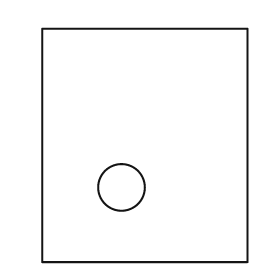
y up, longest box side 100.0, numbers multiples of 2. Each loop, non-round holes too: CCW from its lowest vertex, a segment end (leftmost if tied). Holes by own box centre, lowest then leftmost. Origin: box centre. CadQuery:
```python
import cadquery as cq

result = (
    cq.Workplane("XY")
    .moveTo(-44.0, -50.0)
    .lineTo(44.0, -50.0)
    .lineTo(44.0, 50.0)
    .lineTo(-44.0, 50.0)
    .close()
    .moveTo(-10.0, -18.0)
    .circle(10.0)
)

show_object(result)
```